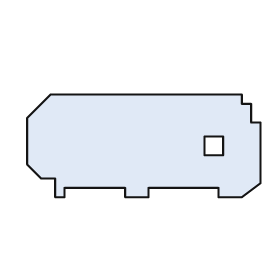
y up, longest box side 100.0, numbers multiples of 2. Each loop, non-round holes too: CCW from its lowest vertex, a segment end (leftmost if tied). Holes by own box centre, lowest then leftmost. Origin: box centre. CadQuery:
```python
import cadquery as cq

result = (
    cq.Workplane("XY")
    .moveTo(-38.0, -22.0)
    .lineTo(-34.0, -22.0)
    .lineTo(-34.0, -18.0)
    .lineTo(-8.0, -18.0)
    .lineTo(-8.0, -22.0)
    .lineTo(2.0, -22.0)
    .lineTo(2.0, -18.0)
    .lineTo(32.0, -18.0)
    .lineTo(32.0, -22.0)
    .lineTo(42.0, -22.0)
    .lineTo(50.0, -16.0)
    .lineTo(50.0, 10.0)
    .lineTo(46.0, 10.0)
    .lineTo(46.0, 18.0)
    .lineTo(42.0, 18.0)
    .lineTo(42.0, 22.0)
    .lineTo(-40.0, 22.0)
    .lineTo(-50.0, 12.0)
    .lineTo(-50.0, -8.0)
    .lineTo(-44.0, -14.0)
    .lineTo(-38.0, -14.0)
    .close()
    .moveTo(26.0, -4.0)
    .lineTo(34.0, -4.0)
    .lineTo(34.0, 4.0)
    .lineTo(26.0, 4.0)
    .close()
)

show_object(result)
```